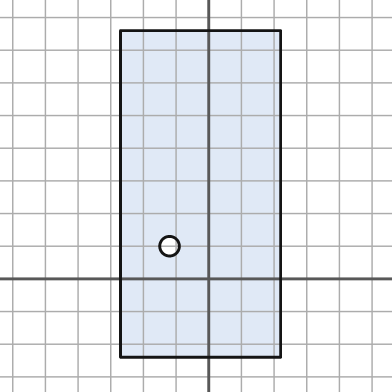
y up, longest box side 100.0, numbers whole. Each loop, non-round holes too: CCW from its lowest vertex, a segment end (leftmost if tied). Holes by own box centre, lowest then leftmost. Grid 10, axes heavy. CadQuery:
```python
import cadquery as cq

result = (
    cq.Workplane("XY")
    .moveTo(-27.0, -24.0)
    .lineTo(22.0, -24.0)
    .lineTo(22.0, 76.0)
    .lineTo(-27.0, 76.0)
    .close()
    .moveTo(-12.0, 10.0)
    .circle(3.0)
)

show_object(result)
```